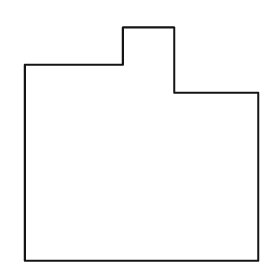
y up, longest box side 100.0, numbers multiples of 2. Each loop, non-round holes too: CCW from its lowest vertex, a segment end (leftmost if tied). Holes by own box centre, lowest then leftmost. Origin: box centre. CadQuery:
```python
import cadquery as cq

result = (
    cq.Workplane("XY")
    .moveTo(-50.0, -50.0)
    .lineTo(50.0, -50.0)
    .lineTo(50.0, 22.0)
    .lineTo(14.0, 22.0)
    .lineTo(14.0, 50.0)
    .lineTo(-8.0, 50.0)
    .lineTo(-8.0, 34.0)
    .lineTo(-50.0, 34.0)
    .close()
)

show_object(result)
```